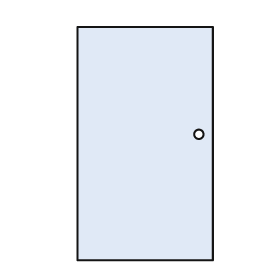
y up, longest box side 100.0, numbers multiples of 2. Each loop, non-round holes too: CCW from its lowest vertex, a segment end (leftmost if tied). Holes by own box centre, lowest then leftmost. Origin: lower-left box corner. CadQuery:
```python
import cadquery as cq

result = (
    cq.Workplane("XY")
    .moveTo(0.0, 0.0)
    .lineTo(58.0, 0.0)
    .lineTo(58.0, 100.0)
    .lineTo(0.0, 100.0)
    .close()
    .moveTo(52.0, 54.0)
    .circle(2.0)
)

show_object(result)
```